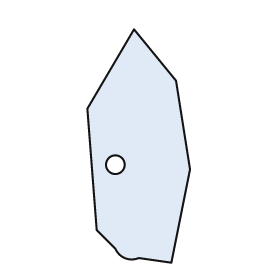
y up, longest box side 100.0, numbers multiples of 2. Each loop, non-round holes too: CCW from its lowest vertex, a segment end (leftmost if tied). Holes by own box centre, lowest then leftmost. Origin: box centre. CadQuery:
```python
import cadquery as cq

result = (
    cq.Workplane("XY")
    .moveTo(14.0, -50.0)
    .lineTo(22.0, -10.0)
    .lineTo(16.0, 28.0)
    .lineTo(-2.0, 50.0)
    .lineTo(-22.0, 16.0)
    .lineTo(-18.0, -36.0)
    .lineTo(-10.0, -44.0)
    .threePointArc((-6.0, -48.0), (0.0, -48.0))
    .close()
    .moveTo(-10.0, -8.0)
    .circle(4.0)
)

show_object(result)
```